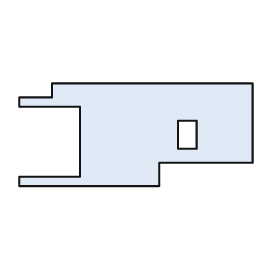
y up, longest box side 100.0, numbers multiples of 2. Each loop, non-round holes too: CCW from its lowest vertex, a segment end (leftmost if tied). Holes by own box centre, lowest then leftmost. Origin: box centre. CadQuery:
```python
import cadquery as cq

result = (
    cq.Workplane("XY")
    .moveTo(-50.0, -22.0)
    .lineTo(10.0, -22.0)
    .lineTo(10.0, -12.0)
    .lineTo(50.0, -12.0)
    .lineTo(50.0, 22.0)
    .lineTo(-36.0, 22.0)
    .lineTo(-36.0, 16.0)
    .lineTo(-50.0, 16.0)
    .lineTo(-50.0, 12.0)
    .lineTo(-24.0, 12.0)
    .lineTo(-24.0, -18.0)
    .lineTo(-50.0, -18.0)
    .close()
    .moveTo(18.0, -6.0)
    .lineTo(26.0, -6.0)
    .lineTo(26.0, 6.0)
    .lineTo(18.0, 6.0)
    .close()
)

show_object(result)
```